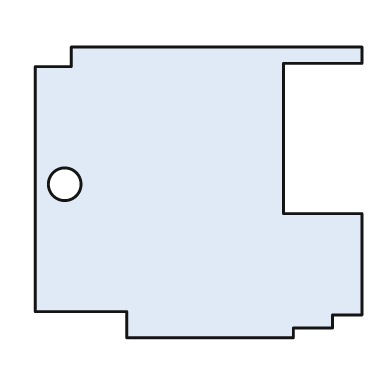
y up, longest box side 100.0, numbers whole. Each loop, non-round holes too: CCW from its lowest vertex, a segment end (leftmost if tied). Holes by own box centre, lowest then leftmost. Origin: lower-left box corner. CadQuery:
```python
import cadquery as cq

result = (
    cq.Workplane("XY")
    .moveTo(28.0, 0.0)
    .lineTo(79.0, 0.0)
    .lineTo(79.0, 3.0)
    .lineTo(91.0, 3.0)
    .lineTo(91.0, 7.0)
    .lineTo(100.0, 7.0)
    .lineTo(100.0, 38.0)
    .lineTo(76.0, 38.0)
    .lineTo(76.0, 84.0)
    .lineTo(100.0, 84.0)
    .lineTo(100.0, 89.0)
    .lineTo(11.0, 89.0)
    .lineTo(11.0, 83.0)
    .lineTo(0.0, 83.0)
    .lineTo(0.0, 8.0)
    .lineTo(28.0, 8.0)
    .close()
    .moveTo(9.0, 47.0)
    .circle(5.0)
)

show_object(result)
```